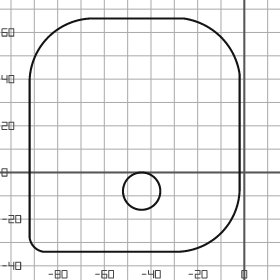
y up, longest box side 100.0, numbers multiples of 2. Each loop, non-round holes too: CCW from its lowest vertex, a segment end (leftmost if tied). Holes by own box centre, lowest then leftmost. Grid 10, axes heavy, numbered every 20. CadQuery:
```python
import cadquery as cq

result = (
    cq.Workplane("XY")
    .moveTo(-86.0, -34.0)
    .lineTo(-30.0, -34.0)
    .threePointArc((-10.0, -26.0), (-2.0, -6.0))
    .lineTo(-2.0, 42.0)
    .threePointArc((-10.0, 58.0), (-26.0, 66.0))
    .lineTo(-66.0, 66.0)
    .threePointArc((-84.0, 58.0), (-92.0, 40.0))
    .lineTo(-92.0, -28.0)
    .threePointArc((-90.0, -32.0), (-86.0, -34.0))
    .close()
    .moveTo(-44.0, -8.0)
    .circle(8.0)
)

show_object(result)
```